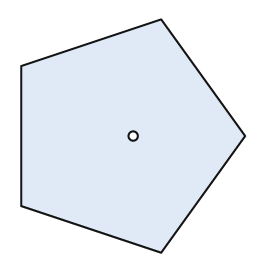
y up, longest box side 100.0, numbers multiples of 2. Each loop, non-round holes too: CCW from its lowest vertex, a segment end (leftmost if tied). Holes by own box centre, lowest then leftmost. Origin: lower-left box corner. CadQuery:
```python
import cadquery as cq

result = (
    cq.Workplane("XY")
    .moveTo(60.0, 0.0)
    .lineTo(96.0, 50.0)
    .lineTo(60.0, 100.0)
    .lineTo(0.0, 80.0)
    .lineTo(0.0, 20.0)
    .close()
    .moveTo(48.0, 50.0)
    .circle(2.0)
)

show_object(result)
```